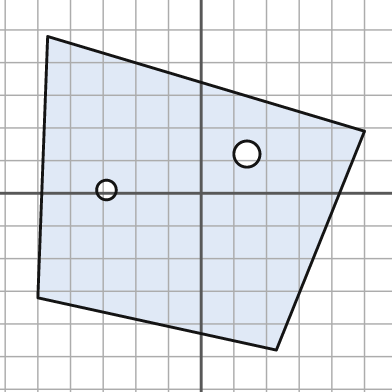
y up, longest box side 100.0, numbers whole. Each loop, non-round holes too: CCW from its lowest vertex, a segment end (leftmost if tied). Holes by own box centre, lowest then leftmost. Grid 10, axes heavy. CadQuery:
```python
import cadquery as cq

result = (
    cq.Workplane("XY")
    .moveTo(23.0, -48.0)
    .lineTo(50.0, 19.0)
    .lineTo(-47.0, 48.0)
    .lineTo(-50.0, -32.0)
    .close()
    .moveTo(-29.0, 1.0)
    .circle(3.0)
    .moveTo(14.0, 12.0)
    .circle(4.0)
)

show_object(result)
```